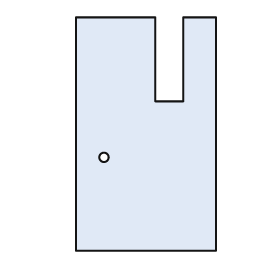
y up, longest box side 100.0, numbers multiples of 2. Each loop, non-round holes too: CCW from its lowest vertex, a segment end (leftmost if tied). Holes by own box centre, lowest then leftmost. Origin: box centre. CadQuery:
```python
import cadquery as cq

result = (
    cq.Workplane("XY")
    .moveTo(-30.0, -50.0)
    .lineTo(30.0, -50.0)
    .lineTo(30.0, 50.0)
    .lineTo(16.0, 50.0)
    .lineTo(16.0, 14.0)
    .lineTo(4.0, 14.0)
    .lineTo(4.0, 50.0)
    .lineTo(-30.0, 50.0)
    .close()
    .moveTo(-18.0, -10.0)
    .circle(2.0)
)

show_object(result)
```